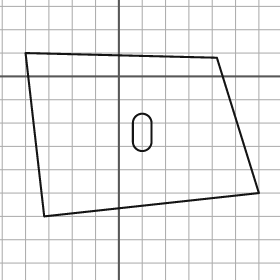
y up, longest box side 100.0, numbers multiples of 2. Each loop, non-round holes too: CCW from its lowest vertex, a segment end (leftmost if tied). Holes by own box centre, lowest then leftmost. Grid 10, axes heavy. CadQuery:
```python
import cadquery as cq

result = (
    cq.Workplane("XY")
    .moveTo(-32.0, -60.0)
    .lineTo(60.0, -50.0)
    .lineTo(42.0, 8.0)
    .lineTo(-40.0, 10.0)
    .close()
    .moveTo(6.0, -28.0)
    .threePointArc((10.0, -32.0), (14.0, -28.0))
    .lineTo(14.0, -20.0)
    .threePointArc((10.0, -16.0), (6.0, -20.0))
    .close()
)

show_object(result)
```